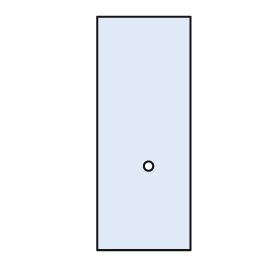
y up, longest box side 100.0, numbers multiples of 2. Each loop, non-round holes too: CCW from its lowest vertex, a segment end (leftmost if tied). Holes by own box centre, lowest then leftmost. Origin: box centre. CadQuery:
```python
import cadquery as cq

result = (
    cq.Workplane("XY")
    .moveTo(-20.0, -50.0)
    .lineTo(20.0, -50.0)
    .lineTo(20.0, 50.0)
    .lineTo(-20.0, 50.0)
    .close()
    .moveTo(2.0, -14.0)
    .circle(2.0)
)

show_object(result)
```